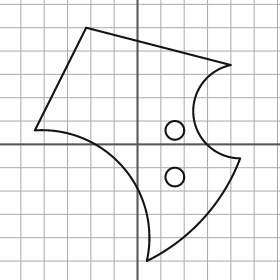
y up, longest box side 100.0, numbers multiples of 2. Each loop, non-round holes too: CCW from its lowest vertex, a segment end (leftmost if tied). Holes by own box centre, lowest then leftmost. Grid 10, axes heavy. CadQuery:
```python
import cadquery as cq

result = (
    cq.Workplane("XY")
    .moveTo(4.0, -50.0)
    .threePointArc((28.0, -32.0), (44.0, -6.0))
    .threePointArc((24.0, 12.0), (40.0, 34.0))
    .lineTo(-22.0, 50.0)
    .lineTo(-44.0, 6.0)
    .threePointArc((-6.0, -10.0), (4.0, -50.0))
    .close()
    .moveTo(16.0, -14.0)
    .circle(4.0)
    .moveTo(16.0, 6.0)
    .circle(4.0)
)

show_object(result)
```